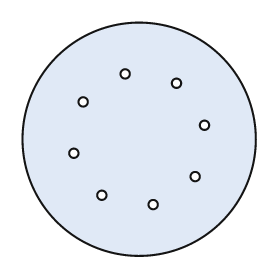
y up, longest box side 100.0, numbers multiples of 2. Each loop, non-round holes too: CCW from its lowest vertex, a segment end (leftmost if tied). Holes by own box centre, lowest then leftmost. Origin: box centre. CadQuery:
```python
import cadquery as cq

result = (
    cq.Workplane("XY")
    .moveTo(0.0, 0.0)
    .circle(50.0)
    .moveTo(6.0, -28.0)
    .circle(2.0)
    .moveTo(-16.0, -24.0)
    .circle(2.0)
    .moveTo(24.0, -16.0)
    .circle(2.0)
    .moveTo(-28.0, -6.0)
    .circle(2.0)
    .moveTo(28.0, 6.0)
    .circle(2.0)
    .moveTo(-24.0, 16.0)
    .circle(2.0)
    .moveTo(16.0, 24.0)
    .circle(2.0)
    .moveTo(-6.0, 28.0)
    .circle(2.0)
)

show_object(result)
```